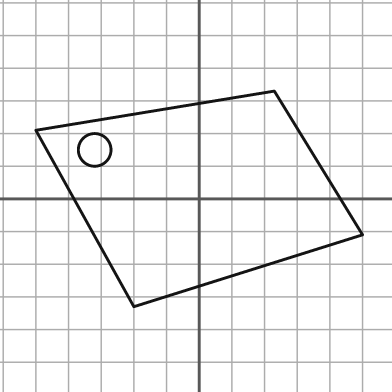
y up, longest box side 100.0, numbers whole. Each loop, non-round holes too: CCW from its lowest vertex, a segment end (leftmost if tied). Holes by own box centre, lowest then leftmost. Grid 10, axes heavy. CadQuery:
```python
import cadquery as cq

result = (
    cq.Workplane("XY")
    .moveTo(-20.0, -33.0)
    .lineTo(50.0, -11.0)
    .lineTo(23.0, 33.0)
    .lineTo(-50.0, 21.0)
    .close()
    .moveTo(-32.0, 15.0)
    .circle(5.0)
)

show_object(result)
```